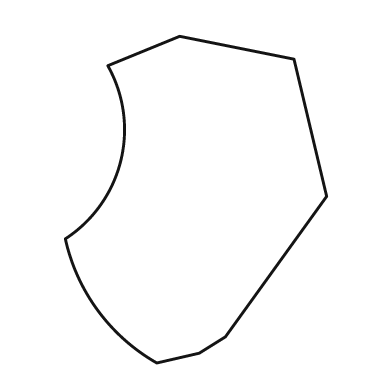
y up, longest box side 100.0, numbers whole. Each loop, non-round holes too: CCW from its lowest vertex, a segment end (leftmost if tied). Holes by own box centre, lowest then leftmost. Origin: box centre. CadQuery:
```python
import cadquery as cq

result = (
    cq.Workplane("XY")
    .moveTo(-12.0, -50.0)
    .lineTo(1.0, -47.0)
    .lineTo(9.0, -42.0)
    .lineTo(40.0, 1.0)
    .lineTo(30.0, 43.0)
    .lineTo(-5.0, 50.0)
    .lineTo(-27.0, 41.0)
    .threePointArc((-23.0, 12.0), (-40.0, -12.0))
    .threePointArc((-30.0, -34.0), (-12.0, -50.0))
    .close()
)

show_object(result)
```